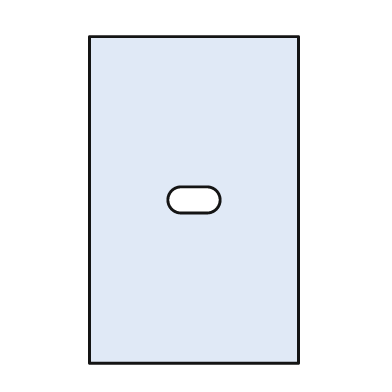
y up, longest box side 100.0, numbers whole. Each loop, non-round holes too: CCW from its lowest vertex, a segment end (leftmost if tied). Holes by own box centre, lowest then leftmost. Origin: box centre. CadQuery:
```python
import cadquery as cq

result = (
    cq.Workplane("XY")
    .moveTo(-32.0, -50.0)
    .lineTo(32.0, -50.0)
    .lineTo(32.0, 50.0)
    .lineTo(-32.0, 50.0)
    .close()
    .moveTo(-4.0, -4.0)
    .lineTo(4.0, -4.0)
    .threePointArc((8.0, 0.0), (4.0, 4.0))
    .lineTo(-4.0, 4.0)
    .threePointArc((-8.0, 0.0), (-4.0, -4.0))
    .close()
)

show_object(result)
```